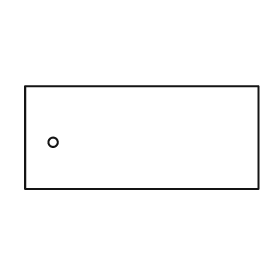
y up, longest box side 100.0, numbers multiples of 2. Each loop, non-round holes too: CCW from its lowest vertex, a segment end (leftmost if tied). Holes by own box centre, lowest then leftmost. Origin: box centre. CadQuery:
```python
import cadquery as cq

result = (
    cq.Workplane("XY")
    .moveTo(-50.0, -22.0)
    .lineTo(50.0, -22.0)
    .lineTo(50.0, 22.0)
    .lineTo(-50.0, 22.0)
    .close()
    .moveTo(-38.0, -2.0)
    .circle(2.0)
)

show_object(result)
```